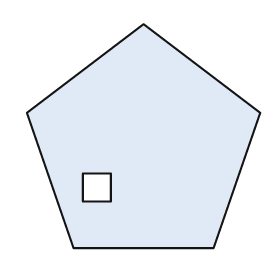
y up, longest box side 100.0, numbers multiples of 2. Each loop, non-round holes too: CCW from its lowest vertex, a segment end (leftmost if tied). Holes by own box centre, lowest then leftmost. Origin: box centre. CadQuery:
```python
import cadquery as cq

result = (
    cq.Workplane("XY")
    .moveTo(-30.0, -48.0)
    .lineTo(30.0, -48.0)
    .lineTo(50.0, 10.0)
    .lineTo(0.0, 48.0)
    .lineTo(-50.0, 10.0)
    .close()
    .moveTo(-26.0, -28.0)
    .lineTo(-14.0, -28.0)
    .lineTo(-14.0, -16.0)
    .lineTo(-26.0, -16.0)
    .close()
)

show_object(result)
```